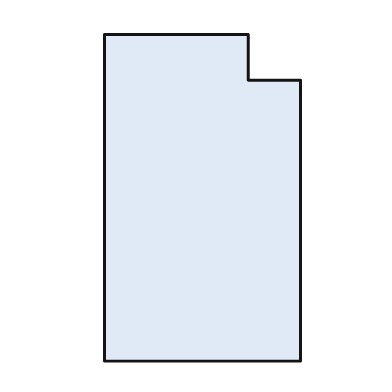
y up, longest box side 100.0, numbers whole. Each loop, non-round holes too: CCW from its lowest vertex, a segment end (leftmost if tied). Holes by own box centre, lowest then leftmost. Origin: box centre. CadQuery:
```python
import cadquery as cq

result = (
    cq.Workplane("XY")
    .moveTo(-30.0, -50.0)
    .lineTo(30.0, -50.0)
    .lineTo(30.0, 36.0)
    .lineTo(14.0, 36.0)
    .lineTo(14.0, 50.0)
    .lineTo(-30.0, 50.0)
    .close()
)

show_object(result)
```